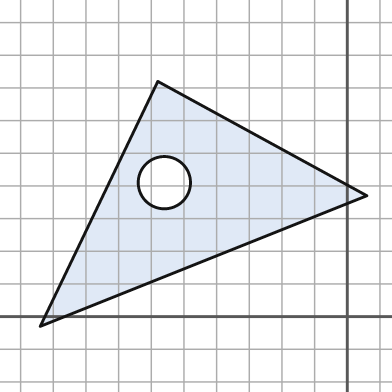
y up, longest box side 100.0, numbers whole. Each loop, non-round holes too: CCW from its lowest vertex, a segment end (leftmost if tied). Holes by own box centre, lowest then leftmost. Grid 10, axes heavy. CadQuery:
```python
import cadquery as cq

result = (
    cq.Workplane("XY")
    .moveTo(-94.0, -3.0)
    .lineTo(6.0, 37.0)
    .lineTo(-58.0, 72.0)
    .close()
    .moveTo(-56.0, 41.0)
    .circle(8.0)
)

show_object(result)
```